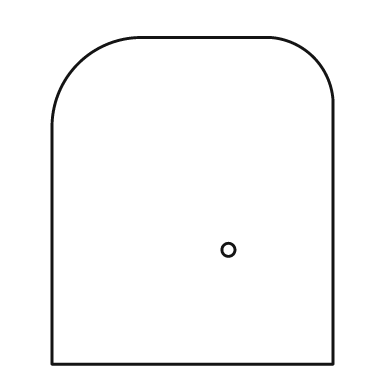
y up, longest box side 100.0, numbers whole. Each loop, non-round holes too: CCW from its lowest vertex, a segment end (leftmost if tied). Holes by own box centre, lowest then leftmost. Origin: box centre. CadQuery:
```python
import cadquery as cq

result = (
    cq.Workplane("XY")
    .moveTo(-43.0, -50.0)
    .lineTo(43.0, -50.0)
    .lineTo(43.0, 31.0)
    .threePointArc((37.0, 44.0), (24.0, 50.0))
    .lineTo(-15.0, 50.0)
    .threePointArc((-35.0, 42.0), (-43.0, 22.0))
    .close()
    .moveTo(11.0, -15.0)
    .circle(2.0)
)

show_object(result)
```